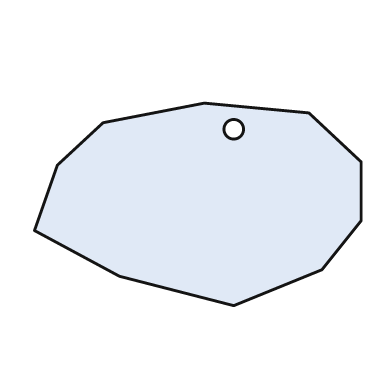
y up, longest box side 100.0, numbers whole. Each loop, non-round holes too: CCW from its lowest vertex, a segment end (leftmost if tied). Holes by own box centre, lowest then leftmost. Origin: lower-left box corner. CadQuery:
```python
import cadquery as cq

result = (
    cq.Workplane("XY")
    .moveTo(61.0, 0.0)
    .lineTo(88.0, 11.0)
    .lineTo(100.0, 26.0)
    .lineTo(100.0, 44.0)
    .lineTo(84.0, 59.0)
    .lineTo(52.0, 62.0)
    .lineTo(21.0, 56.0)
    .lineTo(7.0, 43.0)
    .lineTo(0.0, 23.0)
    .lineTo(26.0, 9.0)
    .close()
    .moveTo(61.0, 54.0)
    .circle(3.0)
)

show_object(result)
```